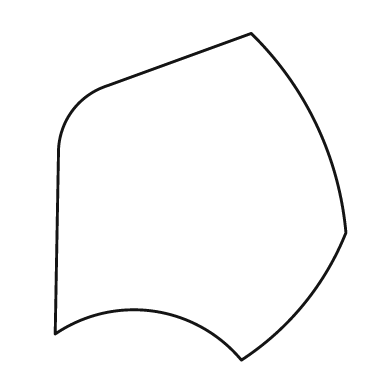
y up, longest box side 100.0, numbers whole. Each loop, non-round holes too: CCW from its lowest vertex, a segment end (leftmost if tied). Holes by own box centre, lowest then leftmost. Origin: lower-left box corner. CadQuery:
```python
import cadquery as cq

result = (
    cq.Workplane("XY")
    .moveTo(57.0, 0.0)
    .threePointArc((76.0, 17.0), (89.0, 39.0))
    .threePointArc((80.0, 72.0), (60.0, 100.0))
    .lineTo(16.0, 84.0)
    .threePointArc((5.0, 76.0), (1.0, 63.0))
    .lineTo(0.0, 8.0)
    .threePointArc((30.0, 15.0), (57.0, 0.0))
    .close()
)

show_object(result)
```